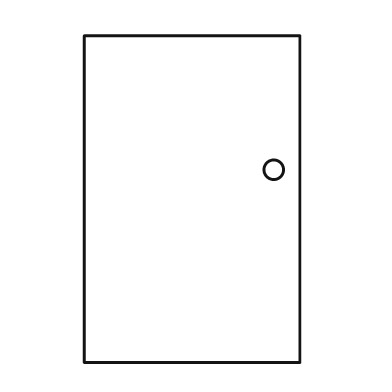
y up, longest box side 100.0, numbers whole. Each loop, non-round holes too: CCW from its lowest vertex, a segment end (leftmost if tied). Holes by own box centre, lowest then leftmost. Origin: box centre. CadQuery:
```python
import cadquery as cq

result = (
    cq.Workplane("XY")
    .moveTo(-33.0, -50.0)
    .lineTo(33.0, -50.0)
    .lineTo(33.0, 50.0)
    .lineTo(-33.0, 50.0)
    .close()
    .moveTo(25.0, 9.0)
    .circle(3.0)
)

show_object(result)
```